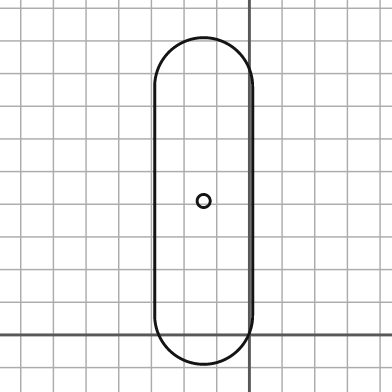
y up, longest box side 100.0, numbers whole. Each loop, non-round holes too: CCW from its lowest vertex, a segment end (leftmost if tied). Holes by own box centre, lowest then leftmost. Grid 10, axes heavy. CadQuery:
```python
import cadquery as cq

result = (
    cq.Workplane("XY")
    .moveTo(-29.0, 6.0)
    .threePointArc((-14.0, -9.0), (1.0, 6.0))
    .lineTo(1.0, 76.0)
    .threePointArc((-14.0, 91.0), (-29.0, 76.0))
    .close()
    .moveTo(-14.0, 41.0)
    .circle(2.0)
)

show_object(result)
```